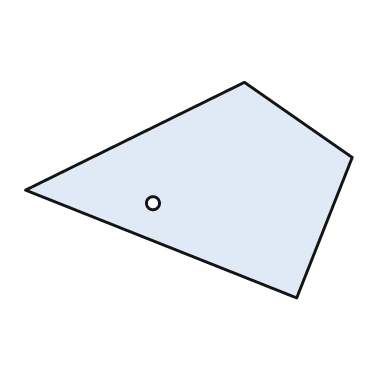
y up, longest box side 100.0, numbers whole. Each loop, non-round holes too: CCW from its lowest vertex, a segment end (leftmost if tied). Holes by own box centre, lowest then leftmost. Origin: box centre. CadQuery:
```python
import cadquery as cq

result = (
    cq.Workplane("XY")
    .moveTo(33.0, -33.0)
    .lineTo(50.0, 10.0)
    .lineTo(17.0, 33.0)
    .lineTo(-50.0, 0.0)
    .close()
    .moveTo(-11.0, -4.0)
    .circle(2.0)
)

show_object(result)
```